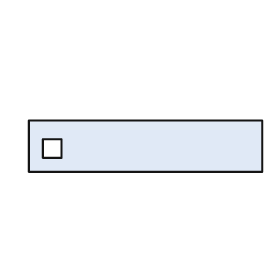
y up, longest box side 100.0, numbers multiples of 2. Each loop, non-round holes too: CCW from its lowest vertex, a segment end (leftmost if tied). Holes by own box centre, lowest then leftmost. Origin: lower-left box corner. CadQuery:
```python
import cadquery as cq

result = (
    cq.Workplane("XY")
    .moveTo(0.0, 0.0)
    .lineTo(100.0, 0.0)
    .lineTo(100.0, 22.0)
    .lineTo(0.0, 22.0)
    .close()
    .moveTo(6.0, 6.0)
    .lineTo(14.0, 6.0)
    .lineTo(14.0, 14.0)
    .lineTo(6.0, 14.0)
    .close()
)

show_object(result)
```